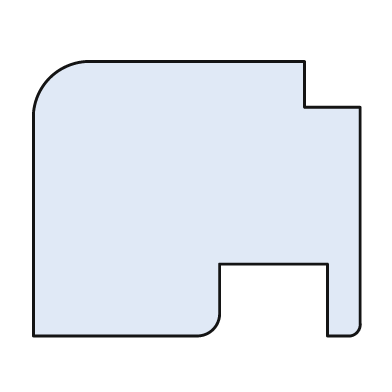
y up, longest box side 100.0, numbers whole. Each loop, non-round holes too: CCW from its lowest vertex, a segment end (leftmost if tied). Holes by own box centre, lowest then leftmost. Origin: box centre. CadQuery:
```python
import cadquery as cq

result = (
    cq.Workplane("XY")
    .moveTo(-50.0, -42.0)
    .lineTo(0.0, -42.0)
    .threePointArc((5.0, -40.0), (7.0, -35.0))
    .lineTo(7.0, -20.0)
    .lineTo(40.0, -20.0)
    .lineTo(40.0, -42.0)
    .lineTo(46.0, -42.0)
    .threePointArc((49.0, -41.0), (50.0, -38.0))
    .lineTo(50.0, 28.0)
    .lineTo(33.0, 28.0)
    .lineTo(33.0, 42.0)
    .lineTo(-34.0, 42.0)
    .threePointArc((-45.0, 37.0), (-50.0, 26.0))
    .close()
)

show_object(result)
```